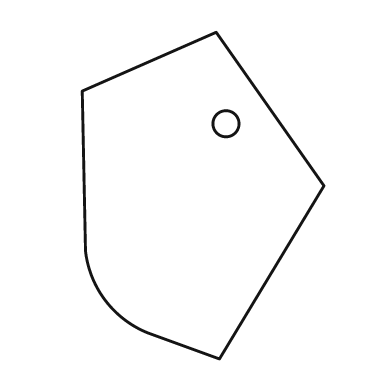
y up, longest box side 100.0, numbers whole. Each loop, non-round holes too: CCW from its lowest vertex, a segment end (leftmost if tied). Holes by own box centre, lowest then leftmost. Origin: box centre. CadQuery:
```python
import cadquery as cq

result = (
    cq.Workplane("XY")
    .moveTo(5.0, -50.0)
    .lineTo(37.0, 3.0)
    .lineTo(4.0, 50.0)
    .lineTo(-37.0, 32.0)
    .lineTo(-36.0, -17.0)
    .threePointArc((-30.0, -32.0), (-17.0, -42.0))
    .close()
    .moveTo(7.0, 22.0)
    .circle(4.0)
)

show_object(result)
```